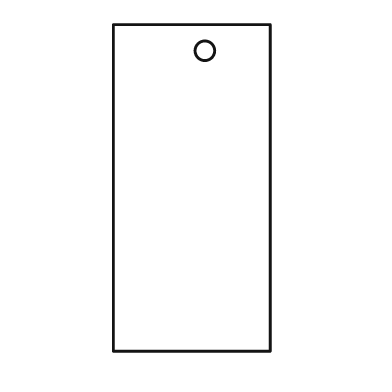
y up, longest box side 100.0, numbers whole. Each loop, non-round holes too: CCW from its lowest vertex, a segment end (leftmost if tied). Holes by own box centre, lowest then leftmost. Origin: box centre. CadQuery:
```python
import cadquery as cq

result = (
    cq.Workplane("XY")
    .moveTo(-24.0, -50.0)
    .lineTo(24.0, -50.0)
    .lineTo(24.0, 50.0)
    .lineTo(-24.0, 50.0)
    .close()
    .moveTo(4.0, 42.0)
    .circle(3.0)
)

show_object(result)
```